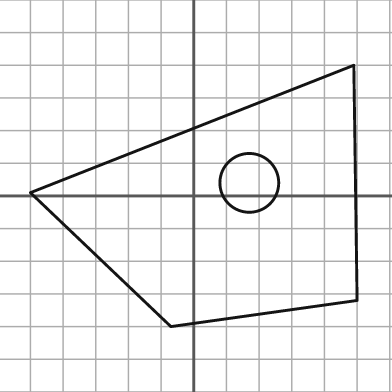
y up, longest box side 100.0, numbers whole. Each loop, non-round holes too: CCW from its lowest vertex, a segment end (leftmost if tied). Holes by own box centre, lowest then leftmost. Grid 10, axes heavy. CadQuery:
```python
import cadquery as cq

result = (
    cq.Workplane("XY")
    .moveTo(-7.0, -40.0)
    .lineTo(50.0, -32.0)
    .lineTo(49.0, 40.0)
    .lineTo(-50.0, 1.0)
    .close()
    .moveTo(17.0, 4.0)
    .circle(9.0)
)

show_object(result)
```